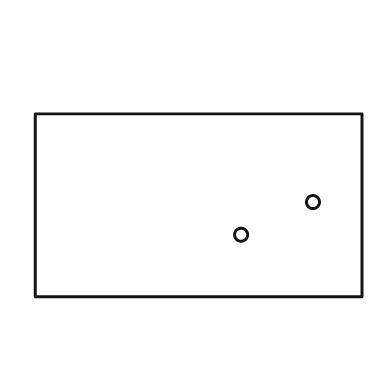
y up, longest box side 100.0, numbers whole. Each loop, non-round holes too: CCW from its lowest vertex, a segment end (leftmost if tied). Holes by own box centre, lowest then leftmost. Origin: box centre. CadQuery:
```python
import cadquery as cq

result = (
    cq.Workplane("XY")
    .moveTo(-50.0, -28.0)
    .lineTo(50.0, -28.0)
    .lineTo(50.0, 28.0)
    .lineTo(-50.0, 28.0)
    .close()
    .moveTo(13.0, -9.0)
    .circle(2.0)
    .moveTo(35.0, 1.0)
    .circle(2.0)
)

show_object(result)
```